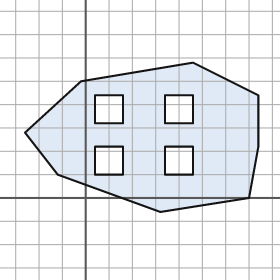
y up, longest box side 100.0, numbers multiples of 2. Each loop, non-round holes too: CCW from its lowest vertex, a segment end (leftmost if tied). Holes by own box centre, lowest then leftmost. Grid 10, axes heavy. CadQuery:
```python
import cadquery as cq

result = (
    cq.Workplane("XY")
    .moveTo(32.0, -6.0)
    .lineTo(70.0, 0.0)
    .lineTo(74.0, 22.0)
    .lineTo(74.0, 44.0)
    .lineTo(46.0, 58.0)
    .lineTo(-2.0, 50.0)
    .lineTo(-26.0, 28.0)
    .lineTo(-12.0, 10.0)
    .close()
    .moveTo(4.0, 10.0)
    .lineTo(16.0, 10.0)
    .lineTo(16.0, 22.0)
    .lineTo(4.0, 22.0)
    .close()
    .moveTo(34.0, 10.0)
    .lineTo(46.0, 10.0)
    .lineTo(46.0, 22.0)
    .lineTo(34.0, 22.0)
    .close()
    .moveTo(4.0, 32.0)
    .lineTo(16.0, 32.0)
    .lineTo(16.0, 44.0)
    .lineTo(4.0, 44.0)
    .close()
    .moveTo(34.0, 32.0)
    .lineTo(46.0, 32.0)
    .lineTo(46.0, 44.0)
    .lineTo(34.0, 44.0)
    .close()
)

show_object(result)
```